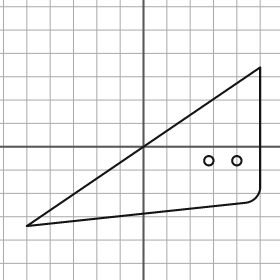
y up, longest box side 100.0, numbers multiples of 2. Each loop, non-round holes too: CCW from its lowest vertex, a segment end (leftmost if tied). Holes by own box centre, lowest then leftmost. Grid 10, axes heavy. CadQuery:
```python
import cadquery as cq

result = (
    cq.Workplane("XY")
    .moveTo(-50.0, -34.0)
    .lineTo(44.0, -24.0)
    .threePointArc((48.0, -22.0), (50.0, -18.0))
    .lineTo(50.0, 34.0)
    .close()
    .moveTo(28.0, -6.0)
    .circle(2.0)
    .moveTo(40.0, -6.0)
    .circle(2.0)
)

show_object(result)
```